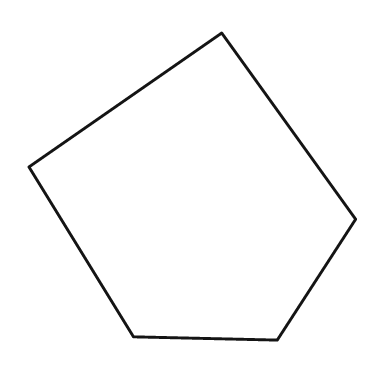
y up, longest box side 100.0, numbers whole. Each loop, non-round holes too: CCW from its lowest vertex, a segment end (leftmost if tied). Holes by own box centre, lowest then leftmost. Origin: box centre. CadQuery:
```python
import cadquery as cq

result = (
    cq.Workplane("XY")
    .moveTo(26.0, -47.0)
    .lineTo(50.0, -10.0)
    .lineTo(9.0, 47.0)
    .lineTo(-50.0, 6.0)
    .lineTo(-18.0, -46.0)
    .close()
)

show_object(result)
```